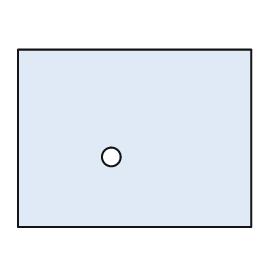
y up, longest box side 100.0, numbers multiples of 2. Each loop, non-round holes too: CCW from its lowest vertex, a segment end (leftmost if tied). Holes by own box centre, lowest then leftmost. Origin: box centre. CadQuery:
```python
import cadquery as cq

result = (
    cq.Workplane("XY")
    .moveTo(-50.0, -38.0)
    .lineTo(50.0, -38.0)
    .lineTo(50.0, 38.0)
    .lineTo(-50.0, 38.0)
    .close()
    .moveTo(-10.0, -8.0)
    .circle(4.0)
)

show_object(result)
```